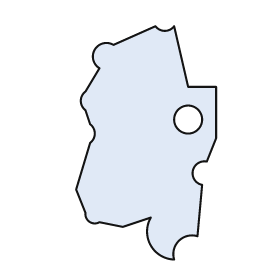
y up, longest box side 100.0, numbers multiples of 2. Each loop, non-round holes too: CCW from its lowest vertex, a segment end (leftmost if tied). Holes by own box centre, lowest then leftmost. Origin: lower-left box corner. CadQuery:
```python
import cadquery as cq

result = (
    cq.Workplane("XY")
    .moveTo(42.0, 0.0)
    .threePointArc((44.0, 8.0), (52.0, 10.0))
    .lineTo(54.0, 32.0)
    .threePointArc((50.0, 38.0), (56.0, 42.0))
    .lineTo(60.0, 52.0)
    .lineTo(60.0, 74.0)
    .lineTo(48.0, 74.0)
    .lineTo(42.0, 100.0)
    .threePointArc((38.0, 98.0), (34.0, 100.0))
    .lineTo(16.0, 92.0)
    .threePointArc((8.0, 90.0), (10.0, 82.0))
    .lineTo(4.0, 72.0)
    .threePointArc((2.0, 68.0), (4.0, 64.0))
    .lineTo(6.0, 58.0)
    .threePointArc((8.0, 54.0), (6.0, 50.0))
    .lineTo(0.0, 30.0)
    .lineTo(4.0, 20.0)
    .threePointArc((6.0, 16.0), (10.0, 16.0))
    .lineTo(20.0, 14.0)
    .lineTo(32.0, 18.0)
    .threePointArc((32.0, 6.0), (42.0, 0.0))
    .close()
    .moveTo(48.0, 60.0)
    .circle(6.0)
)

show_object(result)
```